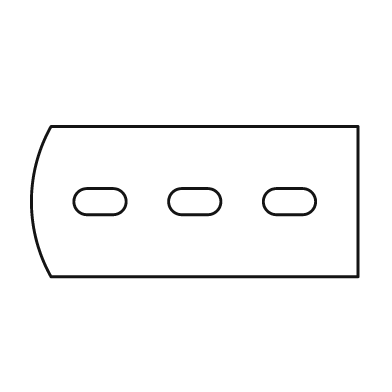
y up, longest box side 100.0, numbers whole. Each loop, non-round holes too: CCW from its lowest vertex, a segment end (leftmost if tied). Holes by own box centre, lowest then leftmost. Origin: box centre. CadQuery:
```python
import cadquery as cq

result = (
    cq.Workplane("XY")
    .moveTo(-44.0, -23.0)
    .lineTo(50.0, -23.0)
    .lineTo(50.0, 23.0)
    .lineTo(-44.0, 23.0)
    .threePointArc((-50.0, 0.0), (-44.0, -23.0))
    .close()
    .moveTo(-33.0, -4.0)
    .lineTo(-25.0, -4.0)
    .threePointArc((-21.0, 0.0), (-25.0, 4.0))
    .lineTo(-33.0, 4.0)
    .threePointArc((-37.0, 0.0), (-33.0, -4.0))
    .close()
    .moveTo(-4.0, -4.0)
    .lineTo(4.0, -4.0)
    .threePointArc((8.0, 0.0), (4.0, 4.0))
    .lineTo(-4.0, 4.0)
    .threePointArc((-8.0, 0.0), (-4.0, -4.0))
    .close()
    .moveTo(25.0, -4.0)
    .lineTo(33.0, -4.0)
    .threePointArc((37.0, 0.0), (33.0, 4.0))
    .lineTo(25.0, 4.0)
    .threePointArc((21.0, 0.0), (25.0, -4.0))
    .close()
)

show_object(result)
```